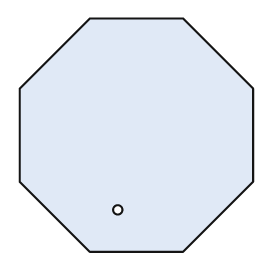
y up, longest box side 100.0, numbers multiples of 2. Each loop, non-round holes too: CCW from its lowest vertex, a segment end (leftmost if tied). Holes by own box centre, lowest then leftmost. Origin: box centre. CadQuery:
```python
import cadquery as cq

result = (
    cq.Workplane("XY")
    .moveTo(-20.0, -50.0)
    .lineTo(20.0, -50.0)
    .lineTo(50.0, -20.0)
    .lineTo(50.0, 20.0)
    .lineTo(20.0, 50.0)
    .lineTo(-20.0, 50.0)
    .lineTo(-50.0, 20.0)
    .lineTo(-50.0, -20.0)
    .close()
    .moveTo(-8.0, -32.0)
    .circle(2.0)
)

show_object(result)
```